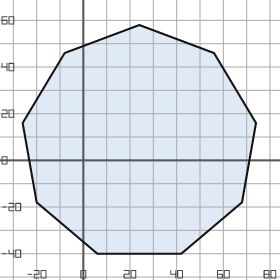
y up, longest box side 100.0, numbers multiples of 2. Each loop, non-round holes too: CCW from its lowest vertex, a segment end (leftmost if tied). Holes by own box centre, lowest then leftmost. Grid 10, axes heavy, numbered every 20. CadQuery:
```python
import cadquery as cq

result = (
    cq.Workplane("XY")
    .moveTo(6.0, -40.0)
    .lineTo(42.0, -40.0)
    .lineTo(68.0, -18.0)
    .lineTo(74.0, 16.0)
    .lineTo(56.0, 46.0)
    .lineTo(24.0, 58.0)
    .lineTo(-8.0, 46.0)
    .lineTo(-26.0, 16.0)
    .lineTo(-20.0, -18.0)
    .close()
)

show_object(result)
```